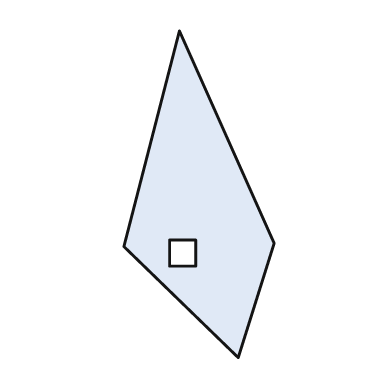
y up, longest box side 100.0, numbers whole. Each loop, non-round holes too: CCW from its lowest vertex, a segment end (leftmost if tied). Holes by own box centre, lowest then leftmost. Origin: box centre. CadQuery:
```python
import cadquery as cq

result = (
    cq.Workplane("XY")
    .moveTo(12.0, -50.0)
    .lineTo(23.0, -15.0)
    .lineTo(-6.0, 50.0)
    .lineTo(-23.0, -16.0)
    .close()
    .moveTo(-9.0, -22.0)
    .lineTo(-1.0, -22.0)
    .lineTo(-1.0, -14.0)
    .lineTo(-9.0, -14.0)
    .close()
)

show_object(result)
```